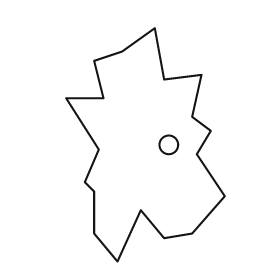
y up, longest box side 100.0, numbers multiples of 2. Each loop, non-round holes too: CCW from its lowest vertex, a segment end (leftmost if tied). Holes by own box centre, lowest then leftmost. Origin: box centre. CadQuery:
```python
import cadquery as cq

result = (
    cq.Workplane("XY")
    .moveTo(-12.0, -50.0)
    .lineTo(-2.0, -28.0)
    .lineTo(8.0, -40.0)
    .lineTo(20.0, -38.0)
    .lineTo(34.0, -22.0)
    .lineTo(22.0, -4.0)
    .lineTo(28.0, 6.0)
    .lineTo(20.0, 12.0)
    .lineTo(24.0, 30.0)
    .lineTo(8.0, 28.0)
    .lineTo(4.0, 50.0)
    .lineTo(-10.0, 40.0)
    .lineTo(-22.0, 36.0)
    .lineTo(-18.0, 20.0)
    .lineTo(-34.0, 20.0)
    .lineTo(-20.0, -2.0)
    .lineTo(-26.0, -16.0)
    .lineTo(-22.0, -20.0)
    .lineTo(-22.0, -38.0)
    .close()
    .moveTo(10.0, 0.0)
    .circle(4.0)
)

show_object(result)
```